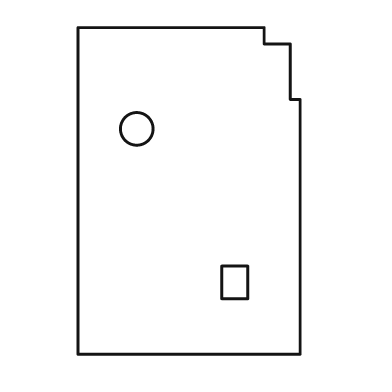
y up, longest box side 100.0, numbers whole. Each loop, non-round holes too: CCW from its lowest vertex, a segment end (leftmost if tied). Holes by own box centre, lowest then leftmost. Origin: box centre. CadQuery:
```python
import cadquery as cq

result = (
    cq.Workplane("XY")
    .moveTo(-34.0, -50.0)
    .lineTo(34.0, -50.0)
    .lineTo(34.0, 28.0)
    .lineTo(31.0, 28.0)
    .lineTo(31.0, 45.0)
    .lineTo(23.0, 45.0)
    .lineTo(23.0, 50.0)
    .lineTo(-34.0, 50.0)
    .close()
    .moveTo(10.0, -33.0)
    .lineTo(18.0, -33.0)
    .lineTo(18.0, -23.0)
    .lineTo(10.0, -23.0)
    .close()
    .moveTo(-16.0, 19.0)
    .circle(5.0)
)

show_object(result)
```